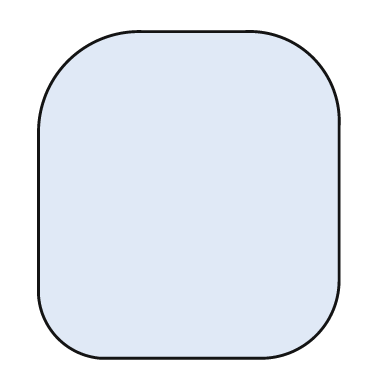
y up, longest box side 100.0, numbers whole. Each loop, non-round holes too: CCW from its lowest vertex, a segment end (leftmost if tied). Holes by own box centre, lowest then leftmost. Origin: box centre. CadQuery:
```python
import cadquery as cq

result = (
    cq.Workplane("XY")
    .moveTo(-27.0, -50.0)
    .lineTo(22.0, -50.0)
    .threePointArc((39.0, -43.0), (46.0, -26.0))
    .lineTo(46.0, 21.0)
    .threePointArc((38.0, 42.0), (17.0, 50.0))
    .lineTo(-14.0, 50.0)
    .threePointArc((-37.0, 41.0), (-46.0, 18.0))
    .lineTo(-46.0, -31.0)
    .threePointArc((-40.0, -44.0), (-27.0, -50.0))
    .close()
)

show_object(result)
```